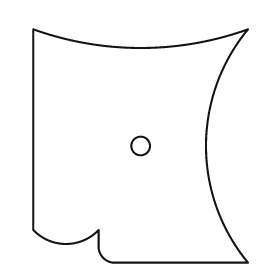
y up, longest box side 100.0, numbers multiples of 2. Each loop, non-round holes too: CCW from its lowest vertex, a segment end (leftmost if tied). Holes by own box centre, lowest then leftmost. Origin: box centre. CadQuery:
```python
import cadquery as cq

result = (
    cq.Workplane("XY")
    .moveTo(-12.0, -50.0)
    .lineTo(46.0, -50.0)
    .threePointArc((28.0, 0.0), (46.0, 50.0))
    .threePointArc((0.0, 42.0), (-46.0, 50.0))
    .lineTo(-46.0, -36.0)
    .threePointArc((-32.0, -42.0), (-18.0, -36.0))
    .lineTo(-18.0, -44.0)
    .threePointArc((-16.0, -48.0), (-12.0, -50.0))
    .close()
    .moveTo(0.0, 0.0)
    .circle(4.0)
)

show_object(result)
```